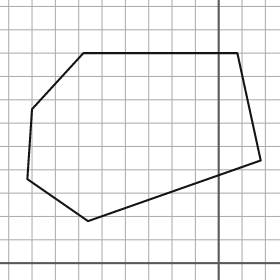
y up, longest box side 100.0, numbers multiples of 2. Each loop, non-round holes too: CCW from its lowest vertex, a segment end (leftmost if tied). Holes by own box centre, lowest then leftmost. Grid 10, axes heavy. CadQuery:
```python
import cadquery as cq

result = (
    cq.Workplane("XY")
    .moveTo(-56.0, 18.0)
    .lineTo(18.0, 44.0)
    .lineTo(8.0, 90.0)
    .lineTo(-58.0, 90.0)
    .lineTo(-80.0, 66.0)
    .lineTo(-82.0, 36.0)
    .close()
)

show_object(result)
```